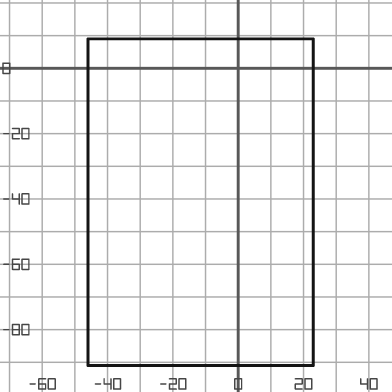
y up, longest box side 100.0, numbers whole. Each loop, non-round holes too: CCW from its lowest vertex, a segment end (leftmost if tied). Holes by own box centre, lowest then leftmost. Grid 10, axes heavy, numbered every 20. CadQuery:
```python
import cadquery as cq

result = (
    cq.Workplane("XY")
    .moveTo(-46.0, -91.0)
    .lineTo(23.0, -91.0)
    .lineTo(23.0, 9.0)
    .lineTo(-46.0, 9.0)
    .close()
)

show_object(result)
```